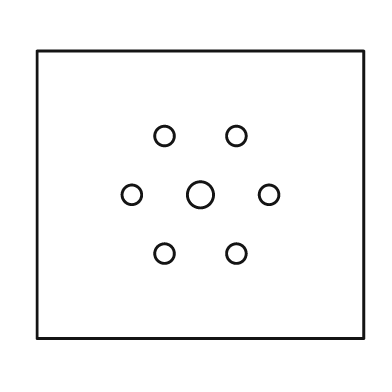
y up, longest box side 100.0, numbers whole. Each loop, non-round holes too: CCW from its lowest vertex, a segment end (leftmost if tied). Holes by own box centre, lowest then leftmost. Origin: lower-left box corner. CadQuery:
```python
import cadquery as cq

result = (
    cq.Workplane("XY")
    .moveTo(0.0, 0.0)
    .lineTo(100.0, 0.0)
    .lineTo(100.0, 88.0)
    .lineTo(0.0, 88.0)
    .close()
    .moveTo(39.0, 26.0)
    .circle(3.0)
    .moveTo(61.0, 26.0)
    .circle(3.0)
    .moveTo(29.0, 44.0)
    .circle(3.0)
    .moveTo(50.0, 44.0)
    .circle(4.0)
    .moveTo(71.0, 44.0)
    .circle(3.0)
    .moveTo(39.0, 62.0)
    .circle(3.0)
    .moveTo(61.0, 62.0)
    .circle(3.0)
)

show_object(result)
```